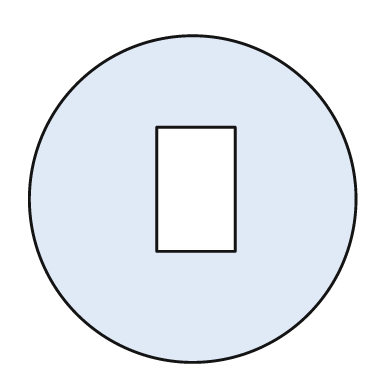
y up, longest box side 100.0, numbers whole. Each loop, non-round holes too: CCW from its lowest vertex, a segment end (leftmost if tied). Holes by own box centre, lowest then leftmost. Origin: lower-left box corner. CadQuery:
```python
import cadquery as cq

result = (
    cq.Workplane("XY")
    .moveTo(50.0, 50.0)
    .circle(50.0)
    .moveTo(39.0, 34.0)
    .lineTo(63.0, 34.0)
    .lineTo(63.0, 72.0)
    .lineTo(39.0, 72.0)
    .close()
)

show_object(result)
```